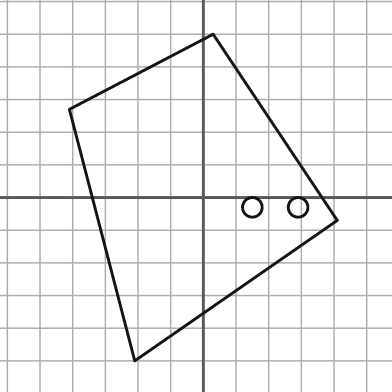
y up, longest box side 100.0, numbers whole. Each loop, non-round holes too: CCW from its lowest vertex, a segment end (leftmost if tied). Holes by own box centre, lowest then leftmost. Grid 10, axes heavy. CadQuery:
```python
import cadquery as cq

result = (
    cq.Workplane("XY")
    .moveTo(-21.0, -50.0)
    .lineTo(41.0, -7.0)
    .lineTo(3.0, 50.0)
    .lineTo(-41.0, 27.0)
    .close()
    .moveTo(15.0, -3.0)
    .circle(3.0)
    .moveTo(29.0, -3.0)
    .circle(3.0)
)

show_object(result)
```